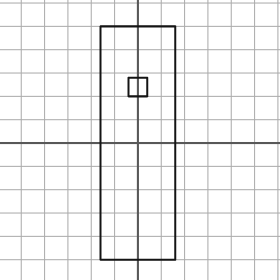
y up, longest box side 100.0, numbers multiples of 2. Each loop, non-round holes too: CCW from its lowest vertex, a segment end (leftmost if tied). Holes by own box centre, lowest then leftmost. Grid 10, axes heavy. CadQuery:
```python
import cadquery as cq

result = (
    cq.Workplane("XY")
    .moveTo(-16.0, -50.0)
    .lineTo(16.0, -50.0)
    .lineTo(16.0, 50.0)
    .lineTo(-16.0, 50.0)
    .close()
    .moveTo(-4.0, 20.0)
    .lineTo(4.0, 20.0)
    .lineTo(4.0, 28.0)
    .lineTo(-4.0, 28.0)
    .close()
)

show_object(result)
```